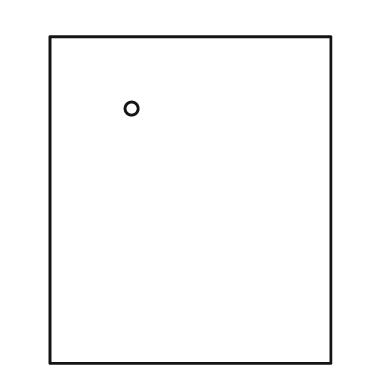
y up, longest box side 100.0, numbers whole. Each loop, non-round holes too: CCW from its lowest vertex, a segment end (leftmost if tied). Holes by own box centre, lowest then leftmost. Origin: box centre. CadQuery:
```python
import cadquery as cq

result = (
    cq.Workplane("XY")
    .moveTo(-43.0, -50.0)
    .lineTo(43.0, -50.0)
    .lineTo(43.0, 50.0)
    .lineTo(-43.0, 50.0)
    .close()
    .moveTo(-18.0, 28.0)
    .circle(2.0)
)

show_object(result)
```